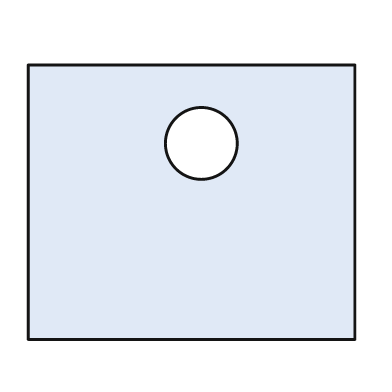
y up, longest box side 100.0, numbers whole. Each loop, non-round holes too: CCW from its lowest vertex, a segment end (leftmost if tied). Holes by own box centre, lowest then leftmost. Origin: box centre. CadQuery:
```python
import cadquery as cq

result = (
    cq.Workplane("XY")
    .moveTo(-50.0, -42.0)
    .lineTo(50.0, -42.0)
    .lineTo(50.0, 42.0)
    .lineTo(-50.0, 42.0)
    .close()
    .moveTo(3.0, 18.0)
    .circle(11.0)
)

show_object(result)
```